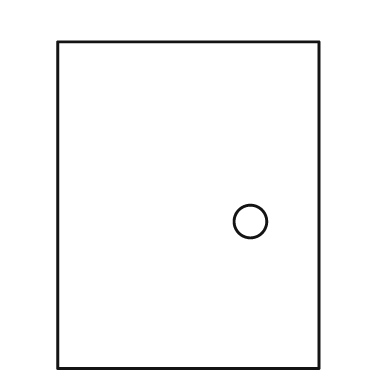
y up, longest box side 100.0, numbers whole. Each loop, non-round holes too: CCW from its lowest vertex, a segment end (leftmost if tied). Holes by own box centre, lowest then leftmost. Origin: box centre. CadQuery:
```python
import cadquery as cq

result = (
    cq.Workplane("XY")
    .moveTo(-40.0, -50.0)
    .lineTo(40.0, -50.0)
    .lineTo(40.0, 50.0)
    .lineTo(-40.0, 50.0)
    .close()
    .moveTo(19.0, -5.0)
    .circle(5.0)
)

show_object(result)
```